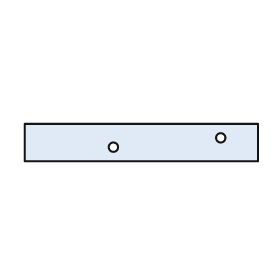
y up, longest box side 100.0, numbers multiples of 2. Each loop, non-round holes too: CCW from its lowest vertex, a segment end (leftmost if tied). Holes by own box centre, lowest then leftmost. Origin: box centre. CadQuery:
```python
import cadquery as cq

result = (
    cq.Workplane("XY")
    .moveTo(-50.0, -8.0)
    .lineTo(50.0, -8.0)
    .lineTo(50.0, 8.0)
    .lineTo(-50.0, 8.0)
    .close()
    .moveTo(-12.0, -2.0)
    .circle(2.0)
    .moveTo(34.0, 2.0)
    .circle(2.0)
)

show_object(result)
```